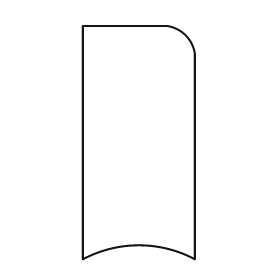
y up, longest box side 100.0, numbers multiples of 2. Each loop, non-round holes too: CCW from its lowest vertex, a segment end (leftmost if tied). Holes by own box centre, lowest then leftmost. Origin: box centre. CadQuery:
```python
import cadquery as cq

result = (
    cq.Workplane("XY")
    .moveTo(-24.0, -50.0)
    .threePointArc((0.0, -44.0), (24.0, -50.0))
    .lineTo(24.0, 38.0)
    .threePointArc((20.0, 46.0), (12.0, 50.0))
    .lineTo(-24.0, 50.0)
    .close()
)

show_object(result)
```